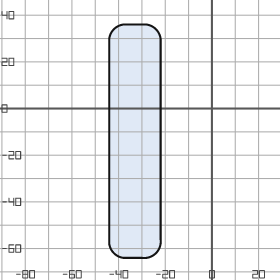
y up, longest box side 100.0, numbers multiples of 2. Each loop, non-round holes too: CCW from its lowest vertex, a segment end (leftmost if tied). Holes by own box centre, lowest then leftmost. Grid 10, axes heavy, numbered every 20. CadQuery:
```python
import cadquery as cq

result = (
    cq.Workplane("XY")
    .moveTo(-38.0, -64.0)
    .lineTo(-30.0, -64.0)
    .threePointArc((-24.0, -62.0), (-22.0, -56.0))
    .lineTo(-22.0, 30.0)
    .threePointArc((-24.0, 34.0), (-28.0, 36.0))
    .lineTo(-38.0, 36.0)
    .threePointArc((-42.0, 34.0), (-44.0, 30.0))
    .lineTo(-44.0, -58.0)
    .threePointArc((-42.0, -62.0), (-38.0, -64.0))
    .close()
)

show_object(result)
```